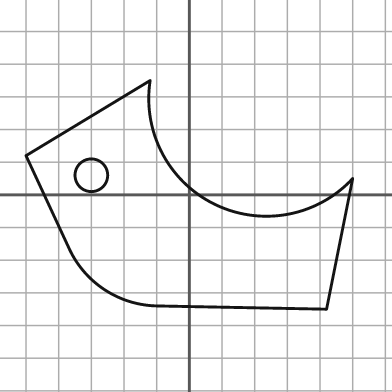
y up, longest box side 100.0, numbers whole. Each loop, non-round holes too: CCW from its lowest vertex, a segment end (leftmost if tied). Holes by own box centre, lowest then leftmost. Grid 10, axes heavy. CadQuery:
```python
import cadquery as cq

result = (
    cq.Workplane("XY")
    .moveTo(42.0, -35.0)
    .lineTo(50.0, 5.0)
    .threePointArc((8.0, -3.0), (-12.0, 35.0))
    .lineTo(-50.0, 12.0)
    .lineTo(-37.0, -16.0)
    .threePointArc((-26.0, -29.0), (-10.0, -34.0))
    .close()
    .moveTo(-30.0, 6.0)
    .circle(5.0)
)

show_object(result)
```